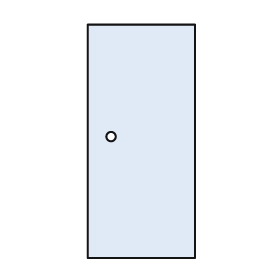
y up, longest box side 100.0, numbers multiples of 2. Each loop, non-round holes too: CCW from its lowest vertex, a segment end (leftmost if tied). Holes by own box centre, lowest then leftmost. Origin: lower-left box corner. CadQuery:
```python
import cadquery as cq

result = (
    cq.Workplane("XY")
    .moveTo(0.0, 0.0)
    .lineTo(46.0, 0.0)
    .lineTo(46.0, 100.0)
    .lineTo(0.0, 100.0)
    .close()
    .moveTo(10.0, 52.0)
    .circle(2.0)
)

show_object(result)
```